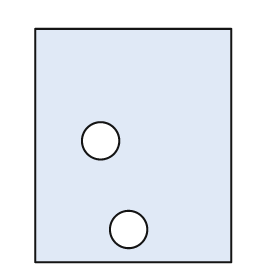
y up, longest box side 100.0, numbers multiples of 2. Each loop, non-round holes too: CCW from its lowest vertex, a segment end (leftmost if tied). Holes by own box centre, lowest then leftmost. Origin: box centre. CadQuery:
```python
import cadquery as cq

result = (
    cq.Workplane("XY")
    .moveTo(-42.0, -50.0)
    .lineTo(42.0, -50.0)
    .lineTo(42.0, 50.0)
    .lineTo(-42.0, 50.0)
    .close()
    .moveTo(-2.0, -36.0)
    .circle(8.0)
    .moveTo(-14.0, 2.0)
    .circle(8.0)
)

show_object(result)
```